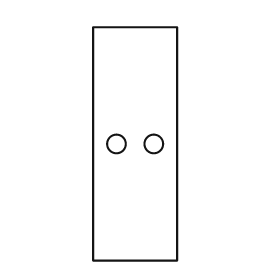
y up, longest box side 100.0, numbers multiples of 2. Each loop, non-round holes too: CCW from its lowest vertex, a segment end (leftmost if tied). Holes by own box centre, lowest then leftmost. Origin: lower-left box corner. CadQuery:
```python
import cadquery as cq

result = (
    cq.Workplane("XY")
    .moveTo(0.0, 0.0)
    .lineTo(36.0, 0.0)
    .lineTo(36.0, 100.0)
    .lineTo(0.0, 100.0)
    .close()
    .moveTo(10.0, 50.0)
    .circle(4.0)
    .moveTo(26.0, 50.0)
    .circle(4.0)
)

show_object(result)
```